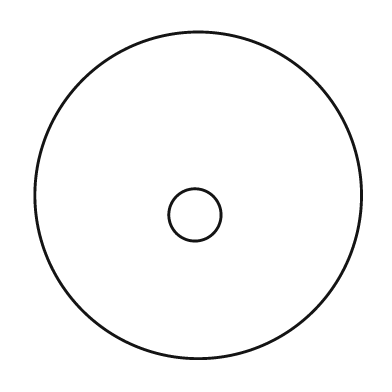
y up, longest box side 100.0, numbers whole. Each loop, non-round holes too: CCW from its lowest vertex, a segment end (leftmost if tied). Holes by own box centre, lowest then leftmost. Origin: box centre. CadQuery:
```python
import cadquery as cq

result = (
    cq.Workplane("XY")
    .moveTo(0.0, 0.0)
    .circle(50.0)
    .moveTo(-1.0, -6.0)
    .circle(8.0)
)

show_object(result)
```